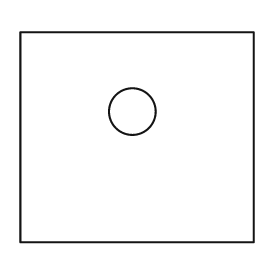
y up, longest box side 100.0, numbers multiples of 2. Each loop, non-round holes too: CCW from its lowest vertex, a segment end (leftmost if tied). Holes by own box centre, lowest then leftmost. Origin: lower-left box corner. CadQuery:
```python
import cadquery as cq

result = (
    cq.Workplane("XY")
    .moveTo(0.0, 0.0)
    .lineTo(100.0, 0.0)
    .lineTo(100.0, 90.0)
    .lineTo(0.0, 90.0)
    .close()
    .moveTo(48.0, 56.0)
    .circle(10.0)
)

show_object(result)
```